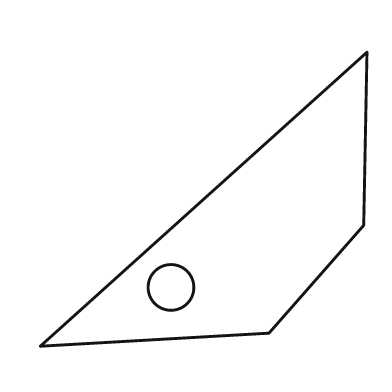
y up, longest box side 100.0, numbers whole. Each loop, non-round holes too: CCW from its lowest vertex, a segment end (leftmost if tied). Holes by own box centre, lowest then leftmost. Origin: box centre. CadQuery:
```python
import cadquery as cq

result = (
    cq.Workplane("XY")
    .moveTo(-50.0, -45.0)
    .lineTo(20.0, -41.0)
    .lineTo(49.0, -8.0)
    .lineTo(50.0, 45.0)
    .close()
    .moveTo(-10.0, -27.0)
    .circle(7.0)
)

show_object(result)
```